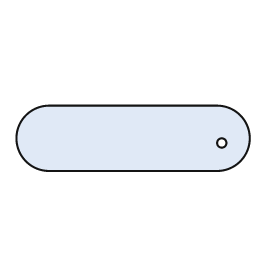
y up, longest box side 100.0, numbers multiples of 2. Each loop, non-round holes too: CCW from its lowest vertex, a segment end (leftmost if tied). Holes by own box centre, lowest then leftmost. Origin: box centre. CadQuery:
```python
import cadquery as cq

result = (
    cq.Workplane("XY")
    .moveTo(-36.0, -14.0)
    .lineTo(36.0, -14.0)
    .threePointArc((50.0, 0.0), (36.0, 14.0))
    .lineTo(-36.0, 14.0)
    .threePointArc((-50.0, 0.0), (-36.0, -14.0))
    .close()
    .moveTo(38.0, -2.0)
    .circle(2.0)
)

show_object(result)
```